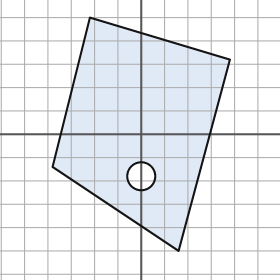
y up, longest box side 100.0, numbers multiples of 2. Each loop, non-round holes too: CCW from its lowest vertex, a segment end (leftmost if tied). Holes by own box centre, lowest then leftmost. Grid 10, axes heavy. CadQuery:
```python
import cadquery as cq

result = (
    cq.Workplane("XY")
    .moveTo(16.0, -50.0)
    .lineTo(38.0, 32.0)
    .lineTo(-22.0, 50.0)
    .lineTo(-38.0, -14.0)
    .close()
    .moveTo(0.0, -18.0)
    .circle(6.0)
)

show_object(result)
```